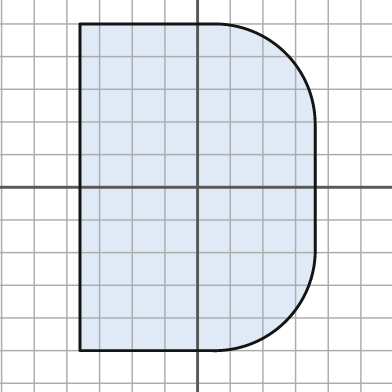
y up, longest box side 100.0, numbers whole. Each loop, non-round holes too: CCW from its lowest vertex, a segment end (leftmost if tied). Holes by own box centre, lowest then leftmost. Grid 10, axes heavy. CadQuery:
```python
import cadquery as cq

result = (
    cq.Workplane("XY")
    .moveTo(-36.0, -50.0)
    .lineTo(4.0, -50.0)
    .threePointArc((27.0, -41.0), (36.0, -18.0))
    .lineTo(36.0, 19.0)
    .threePointArc((27.0, 41.0), (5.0, 50.0))
    .lineTo(-36.0, 50.0)
    .close()
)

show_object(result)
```